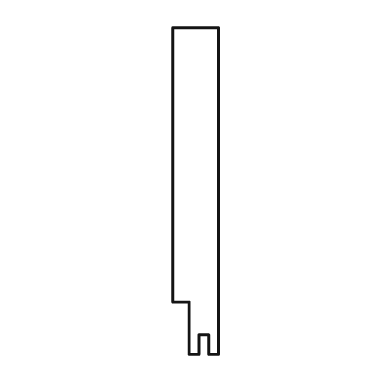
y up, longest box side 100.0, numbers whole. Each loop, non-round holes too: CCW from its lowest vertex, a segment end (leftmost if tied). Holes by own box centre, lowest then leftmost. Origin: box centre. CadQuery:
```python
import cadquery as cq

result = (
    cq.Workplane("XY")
    .moveTo(-2.0, -50.0)
    .lineTo(1.0, -50.0)
    .lineTo(1.0, -44.0)
    .lineTo(4.0, -44.0)
    .lineTo(4.0, -50.0)
    .lineTo(7.0, -50.0)
    .lineTo(7.0, 50.0)
    .lineTo(-7.0, 50.0)
    .lineTo(-7.0, -34.0)
    .lineTo(-2.0, -34.0)
    .close()
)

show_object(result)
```